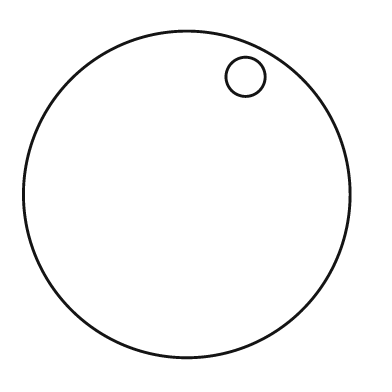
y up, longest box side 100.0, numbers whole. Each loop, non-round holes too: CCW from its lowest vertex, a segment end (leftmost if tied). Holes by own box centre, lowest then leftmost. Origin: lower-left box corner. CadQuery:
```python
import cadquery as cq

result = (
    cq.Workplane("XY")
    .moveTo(50.0, 50.0)
    .circle(50.0)
    .moveTo(68.0, 86.0)
    .circle(6.0)
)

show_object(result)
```